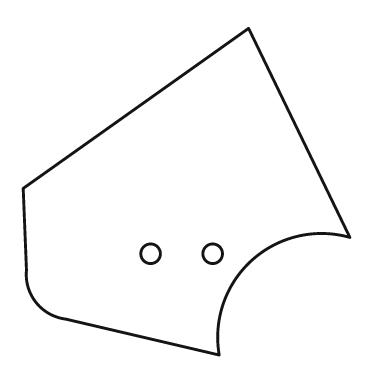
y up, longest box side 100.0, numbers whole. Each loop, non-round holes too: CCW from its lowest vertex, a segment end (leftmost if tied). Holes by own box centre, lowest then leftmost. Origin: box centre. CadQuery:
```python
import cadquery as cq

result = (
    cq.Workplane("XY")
    .moveTo(10.0, -50.0)
    .threePointArc((20.0, -21.0), (50.0, -14.0))
    .lineTo(19.0, 50.0)
    .lineTo(-50.0, 1.0)
    .lineTo(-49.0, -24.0)
    .threePointArc((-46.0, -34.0), (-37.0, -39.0))
    .close()
    .moveTo(-11.0, -19.0)
    .circle(3.0)
    .moveTo(8.0, -19.0)
    .circle(3.0)
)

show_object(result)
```